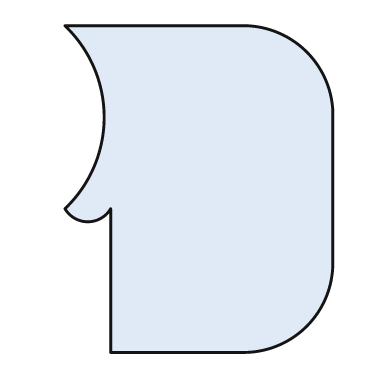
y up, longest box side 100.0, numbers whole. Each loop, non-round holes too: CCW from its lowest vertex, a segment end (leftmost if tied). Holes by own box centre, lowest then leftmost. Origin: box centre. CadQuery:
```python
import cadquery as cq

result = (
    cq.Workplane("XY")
    .moveTo(-27.0, -50.0)
    .lineTo(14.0, -50.0)
    .threePointArc((33.0, -42.0), (41.0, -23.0))
    .lineTo(41.0, 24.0)
    .threePointArc((33.0, 42.0), (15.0, 50.0))
    .lineTo(-41.0, 50.0)
    .threePointArc((-29.0, 22.0), (-41.0, -6.0))
    .threePointArc((-34.0, -10.0), (-27.0, -6.0))
    .close()
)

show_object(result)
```